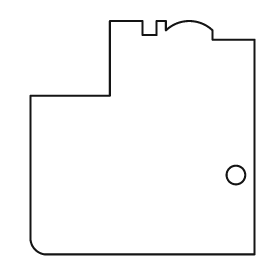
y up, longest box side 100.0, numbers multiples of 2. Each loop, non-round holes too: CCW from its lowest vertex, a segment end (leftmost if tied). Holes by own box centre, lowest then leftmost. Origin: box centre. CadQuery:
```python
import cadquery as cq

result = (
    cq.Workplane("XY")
    .moveTo(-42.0, -50.0)
    .lineTo(48.0, -50.0)
    .lineTo(48.0, 42.0)
    .lineTo(30.0, 42.0)
    .lineTo(30.0, 46.0)
    .threePointArc((20.0, 50.0), (10.0, 46.0))
    .lineTo(10.0, 50.0)
    .lineTo(6.0, 50.0)
    .lineTo(6.0, 44.0)
    .lineTo(0.0, 44.0)
    .lineTo(0.0, 50.0)
    .lineTo(-14.0, 50.0)
    .lineTo(-14.0, 18.0)
    .lineTo(-48.0, 18.0)
    .lineTo(-48.0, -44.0)
    .threePointArc((-46.0, -48.0), (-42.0, -50.0))
    .close()
    .moveTo(40.0, -16.0)
    .circle(4.0)
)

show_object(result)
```